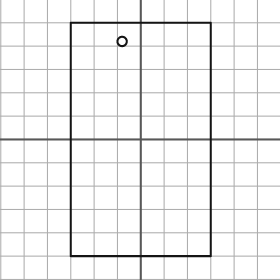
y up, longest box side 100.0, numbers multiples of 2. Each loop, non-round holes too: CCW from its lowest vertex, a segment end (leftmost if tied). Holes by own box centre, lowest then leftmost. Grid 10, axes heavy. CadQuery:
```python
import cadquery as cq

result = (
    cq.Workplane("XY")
    .moveTo(-30.0, -50.0)
    .lineTo(30.0, -50.0)
    .lineTo(30.0, 50.0)
    .lineTo(-30.0, 50.0)
    .close()
    .moveTo(-8.0, 42.0)
    .circle(2.0)
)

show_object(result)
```